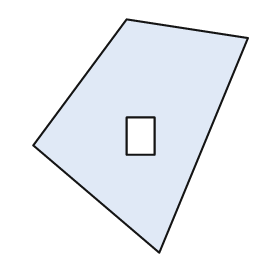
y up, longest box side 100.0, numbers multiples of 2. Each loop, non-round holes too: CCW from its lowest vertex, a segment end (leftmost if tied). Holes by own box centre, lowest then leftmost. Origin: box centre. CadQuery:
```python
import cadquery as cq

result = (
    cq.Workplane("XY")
    .moveTo(8.0, -50.0)
    .lineTo(46.0, 42.0)
    .lineTo(-6.0, 50.0)
    .lineTo(-46.0, -4.0)
    .close()
    .moveTo(-6.0, -8.0)
    .lineTo(6.0, -8.0)
    .lineTo(6.0, 8.0)
    .lineTo(-6.0, 8.0)
    .close()
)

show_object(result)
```